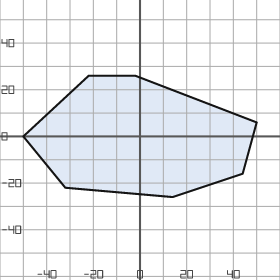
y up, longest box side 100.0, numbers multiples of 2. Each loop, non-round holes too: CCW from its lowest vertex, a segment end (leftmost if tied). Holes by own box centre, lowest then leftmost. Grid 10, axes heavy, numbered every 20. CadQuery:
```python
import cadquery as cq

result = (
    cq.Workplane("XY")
    .moveTo(14.0, -26.0)
    .lineTo(44.0, -16.0)
    .lineTo(50.0, 6.0)
    .lineTo(-2.0, 26.0)
    .lineTo(-22.0, 26.0)
    .lineTo(-50.0, 0.0)
    .lineTo(-32.0, -22.0)
    .close()
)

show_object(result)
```